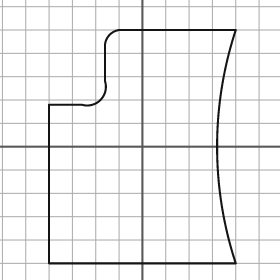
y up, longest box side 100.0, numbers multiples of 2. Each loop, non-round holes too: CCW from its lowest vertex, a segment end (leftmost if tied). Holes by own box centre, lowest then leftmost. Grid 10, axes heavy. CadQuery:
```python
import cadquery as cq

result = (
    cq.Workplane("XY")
    .moveTo(-40.0, -50.0)
    .lineTo(40.0, -50.0)
    .threePointArc((32.0, 0.0), (40.0, 50.0))
    .lineTo(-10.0, 50.0)
    .threePointArc((-14.0, 48.0), (-16.0, 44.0))
    .lineTo(-16.0, 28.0)
    .threePointArc((-18.0, 20.0), (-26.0, 18.0))
    .lineTo(-40.0, 18.0)
    .close()
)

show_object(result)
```